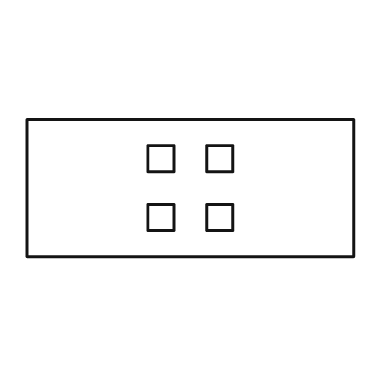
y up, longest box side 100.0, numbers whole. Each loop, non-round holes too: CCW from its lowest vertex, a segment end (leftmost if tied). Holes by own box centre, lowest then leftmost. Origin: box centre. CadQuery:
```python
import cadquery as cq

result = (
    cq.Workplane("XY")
    .moveTo(-50.0, -21.0)
    .lineTo(50.0, -21.0)
    .lineTo(50.0, 21.0)
    .lineTo(-50.0, 21.0)
    .close()
    .moveTo(-13.0, -13.0)
    .lineTo(-5.0, -13.0)
    .lineTo(-5.0, -5.0)
    .lineTo(-13.0, -5.0)
    .close()
    .moveTo(5.0, -13.0)
    .lineTo(13.0, -13.0)
    .lineTo(13.0, -5.0)
    .lineTo(5.0, -5.0)
    .close()
    .moveTo(-13.0, 5.0)
    .lineTo(-5.0, 5.0)
    .lineTo(-5.0, 13.0)
    .lineTo(-13.0, 13.0)
    .close()
    .moveTo(5.0, 5.0)
    .lineTo(13.0, 5.0)
    .lineTo(13.0, 13.0)
    .lineTo(5.0, 13.0)
    .close()
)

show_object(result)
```